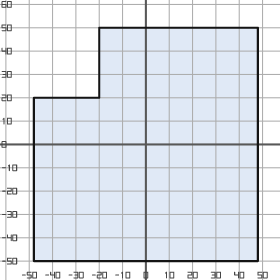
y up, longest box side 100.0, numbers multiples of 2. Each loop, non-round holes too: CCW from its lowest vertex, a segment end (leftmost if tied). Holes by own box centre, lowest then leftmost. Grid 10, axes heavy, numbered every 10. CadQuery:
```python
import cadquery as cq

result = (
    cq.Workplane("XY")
    .moveTo(-48.0, -50.0)
    .lineTo(48.0, -50.0)
    .lineTo(48.0, 50.0)
    .lineTo(-20.0, 50.0)
    .lineTo(-20.0, 20.0)
    .lineTo(-48.0, 20.0)
    .close()
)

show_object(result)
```